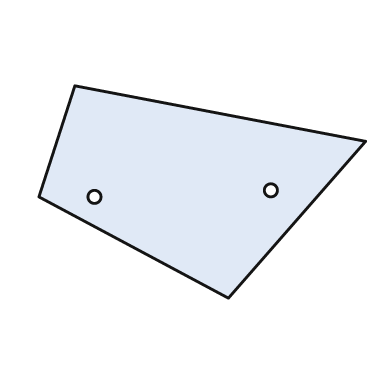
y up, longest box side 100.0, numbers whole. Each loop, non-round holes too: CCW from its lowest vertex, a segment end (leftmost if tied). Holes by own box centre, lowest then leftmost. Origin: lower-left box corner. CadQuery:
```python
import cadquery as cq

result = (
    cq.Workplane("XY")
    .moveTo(58.0, 0.0)
    .lineTo(100.0, 48.0)
    .lineTo(11.0, 65.0)
    .lineTo(0.0, 31.0)
    .close()
    .moveTo(17.0, 31.0)
    .circle(2.0)
    .moveTo(71.0, 33.0)
    .circle(2.0)
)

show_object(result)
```